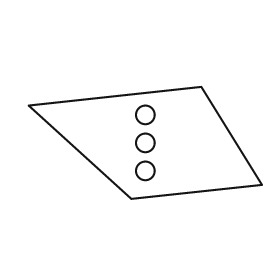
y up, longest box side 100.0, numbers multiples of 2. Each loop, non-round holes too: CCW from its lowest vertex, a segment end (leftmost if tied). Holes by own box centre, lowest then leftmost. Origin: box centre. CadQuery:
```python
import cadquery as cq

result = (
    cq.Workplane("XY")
    .moveTo(-6.0, -24.0)
    .lineTo(50.0, -18.0)
    .lineTo(24.0, 24.0)
    .lineTo(-50.0, 16.0)
    .close()
    .moveTo(0.0, -12.0)
    .circle(4.0)
    .moveTo(0.0, 0.0)
    .circle(4.0)
    .moveTo(0.0, 12.0)
    .circle(4.0)
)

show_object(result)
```